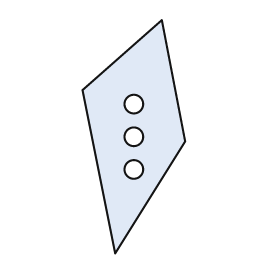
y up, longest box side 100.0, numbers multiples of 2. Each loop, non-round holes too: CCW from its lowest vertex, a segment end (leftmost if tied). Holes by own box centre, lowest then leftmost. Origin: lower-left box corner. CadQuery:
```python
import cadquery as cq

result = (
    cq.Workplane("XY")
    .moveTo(14.0, 0.0)
    .lineTo(44.0, 48.0)
    .lineTo(34.0, 100.0)
    .lineTo(0.0, 70.0)
    .close()
    .moveTo(22.0, 36.0)
    .circle(4.0)
    .moveTo(22.0, 50.0)
    .circle(4.0)
    .moveTo(22.0, 64.0)
    .circle(4.0)
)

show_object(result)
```